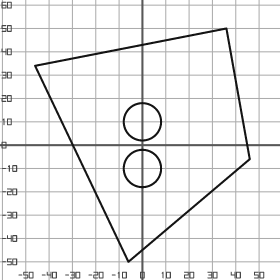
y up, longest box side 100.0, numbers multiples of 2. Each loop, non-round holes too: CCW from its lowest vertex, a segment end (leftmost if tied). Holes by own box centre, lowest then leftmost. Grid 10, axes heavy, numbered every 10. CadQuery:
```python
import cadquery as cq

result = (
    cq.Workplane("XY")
    .moveTo(-6.0, -50.0)
    .lineTo(46.0, -6.0)
    .lineTo(36.0, 50.0)
    .lineTo(-46.0, 34.0)
    .close()
    .moveTo(0.0, -10.0)
    .circle(8.0)
    .moveTo(0.0, 10.0)
    .circle(8.0)
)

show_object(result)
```